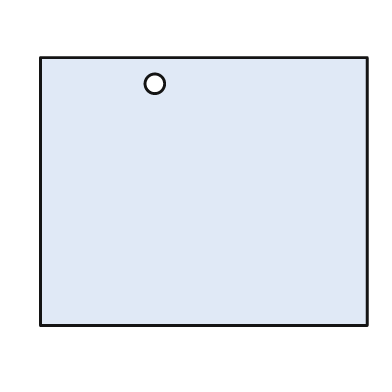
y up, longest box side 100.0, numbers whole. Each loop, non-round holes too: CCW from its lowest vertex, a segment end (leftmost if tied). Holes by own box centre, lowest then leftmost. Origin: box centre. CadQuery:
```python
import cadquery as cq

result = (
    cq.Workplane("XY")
    .moveTo(-50.0, -41.0)
    .lineTo(50.0, -41.0)
    .lineTo(50.0, 41.0)
    .lineTo(-50.0, 41.0)
    .close()
    .moveTo(-15.0, 33.0)
    .circle(3.0)
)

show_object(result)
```